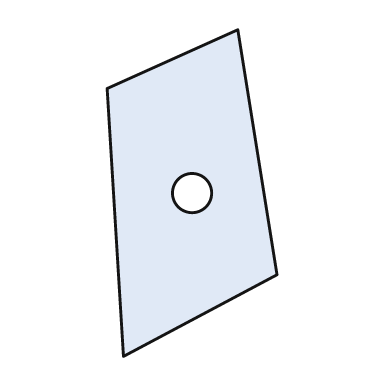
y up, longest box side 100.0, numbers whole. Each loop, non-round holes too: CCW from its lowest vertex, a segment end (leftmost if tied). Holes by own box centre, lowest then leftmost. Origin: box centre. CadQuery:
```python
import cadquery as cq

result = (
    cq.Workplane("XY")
    .moveTo(-21.0, -50.0)
    .lineTo(26.0, -25.0)
    .lineTo(14.0, 50.0)
    .lineTo(-26.0, 32.0)
    .close()
    .moveTo(0.0, 0.0)
    .circle(6.0)
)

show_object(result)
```